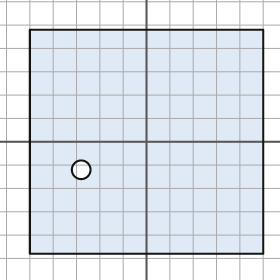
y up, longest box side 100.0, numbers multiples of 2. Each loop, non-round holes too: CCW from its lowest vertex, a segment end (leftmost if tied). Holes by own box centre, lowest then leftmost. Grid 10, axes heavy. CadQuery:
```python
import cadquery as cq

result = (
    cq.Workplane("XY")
    .moveTo(-50.0, -48.0)
    .lineTo(50.0, -48.0)
    .lineTo(50.0, 48.0)
    .lineTo(-50.0, 48.0)
    .close()
    .moveTo(-28.0, -12.0)
    .circle(4.0)
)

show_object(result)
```